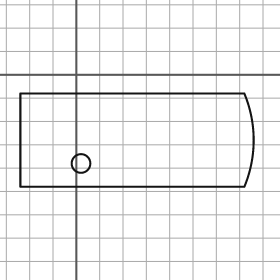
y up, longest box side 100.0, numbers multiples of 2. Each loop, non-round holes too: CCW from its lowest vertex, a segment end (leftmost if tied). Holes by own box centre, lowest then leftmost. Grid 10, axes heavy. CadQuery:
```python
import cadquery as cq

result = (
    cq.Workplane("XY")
    .moveTo(-24.0, -48.0)
    .lineTo(72.0, -48.0)
    .threePointArc((76.0, -28.0), (72.0, -8.0))
    .lineTo(-24.0, -8.0)
    .close()
    .moveTo(2.0, -38.0)
    .circle(4.0)
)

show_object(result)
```